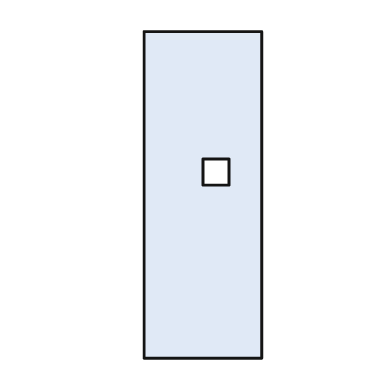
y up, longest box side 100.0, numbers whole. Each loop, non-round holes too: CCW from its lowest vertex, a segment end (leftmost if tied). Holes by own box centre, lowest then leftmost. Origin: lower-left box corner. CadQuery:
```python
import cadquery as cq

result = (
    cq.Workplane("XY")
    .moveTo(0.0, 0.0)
    .lineTo(36.0, 0.0)
    .lineTo(36.0, 100.0)
    .lineTo(0.0, 100.0)
    .close()
    .moveTo(18.0, 53.0)
    .lineTo(26.0, 53.0)
    .lineTo(26.0, 61.0)
    .lineTo(18.0, 61.0)
    .close()
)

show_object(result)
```